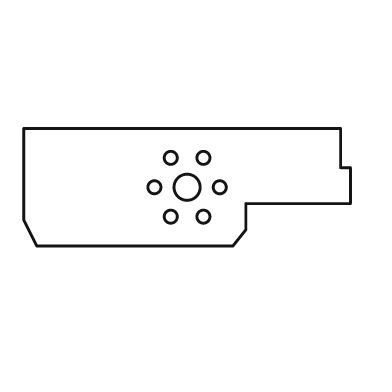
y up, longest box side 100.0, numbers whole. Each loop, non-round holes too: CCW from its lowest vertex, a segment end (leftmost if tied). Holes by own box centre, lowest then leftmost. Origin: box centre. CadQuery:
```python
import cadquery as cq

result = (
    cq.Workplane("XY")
    .moveTo(-46.0, -18.0)
    .lineTo(14.0, -18.0)
    .lineTo(18.0, -13.0)
    .lineTo(18.0, -5.0)
    .lineTo(50.0, -5.0)
    .lineTo(50.0, 6.0)
    .lineTo(47.0, 6.0)
    .lineTo(47.0, 18.0)
    .lineTo(-50.0, 18.0)
    .lineTo(-50.0, -10.0)
    .close()
    .moveTo(-5.0, -9.0)
    .circle(2.0)
    .moveTo(5.0, -9.0)
    .circle(2.0)
    .moveTo(-10.0, 0.0)
    .circle(2.0)
    .moveTo(0.0, 0.0)
    .circle(4.0)
    .moveTo(10.0, 0.0)
    .circle(2.0)
    .moveTo(-5.0, 9.0)
    .circle(2.0)
    .moveTo(5.0, 9.0)
    .circle(2.0)
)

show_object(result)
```